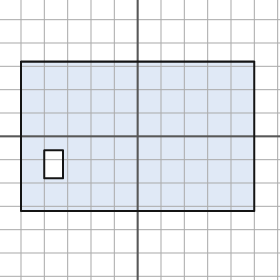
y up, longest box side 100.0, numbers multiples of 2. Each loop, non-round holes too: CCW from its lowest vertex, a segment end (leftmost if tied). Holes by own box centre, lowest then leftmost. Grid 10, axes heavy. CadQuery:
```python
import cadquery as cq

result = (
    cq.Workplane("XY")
    .moveTo(-50.0, -32.0)
    .lineTo(50.0, -32.0)
    .lineTo(50.0, 32.0)
    .lineTo(-50.0, 32.0)
    .close()
    .moveTo(-40.0, -18.0)
    .lineTo(-32.0, -18.0)
    .lineTo(-32.0, -6.0)
    .lineTo(-40.0, -6.0)
    .close()
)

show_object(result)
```